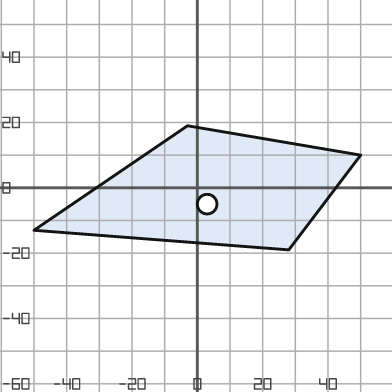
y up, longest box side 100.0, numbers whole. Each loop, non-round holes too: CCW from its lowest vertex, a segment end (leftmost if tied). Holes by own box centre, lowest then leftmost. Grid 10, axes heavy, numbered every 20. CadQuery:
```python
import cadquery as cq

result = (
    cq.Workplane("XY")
    .moveTo(28.0, -19.0)
    .lineTo(50.0, 10.0)
    .lineTo(-3.0, 19.0)
    .lineTo(-50.0, -13.0)
    .close()
    .moveTo(3.0, -5.0)
    .circle(3.0)
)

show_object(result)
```